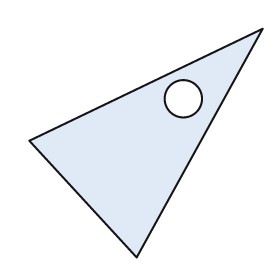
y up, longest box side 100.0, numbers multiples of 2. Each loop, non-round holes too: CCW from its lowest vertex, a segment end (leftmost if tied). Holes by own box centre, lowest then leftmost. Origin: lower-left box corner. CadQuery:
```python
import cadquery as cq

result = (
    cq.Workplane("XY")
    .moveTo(46.0, 0.0)
    .lineTo(100.0, 98.0)
    .lineTo(0.0, 50.0)
    .close()
    .moveTo(66.0, 68.0)
    .circle(8.0)
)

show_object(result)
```